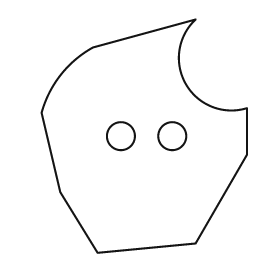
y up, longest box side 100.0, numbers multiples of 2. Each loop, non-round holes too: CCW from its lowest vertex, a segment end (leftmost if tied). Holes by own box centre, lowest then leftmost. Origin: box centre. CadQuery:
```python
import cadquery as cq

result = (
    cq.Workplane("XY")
    .moveTo(-20.0, -50.0)
    .lineTo(22.0, -46.0)
    .lineTo(44.0, -8.0)
    .lineTo(44.0, 12.0)
    .threePointArc((18.0, 22.0), (22.0, 50.0))
    .lineTo(-22.0, 38.0)
    .threePointArc((-36.0, 26.0), (-44.0, 10.0))
    .lineTo(-36.0, -24.0)
    .close()
    .moveTo(-10.0, 0.0)
    .circle(6.0)
    .moveTo(12.0, 0.0)
    .circle(6.0)
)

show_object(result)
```